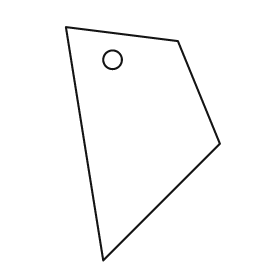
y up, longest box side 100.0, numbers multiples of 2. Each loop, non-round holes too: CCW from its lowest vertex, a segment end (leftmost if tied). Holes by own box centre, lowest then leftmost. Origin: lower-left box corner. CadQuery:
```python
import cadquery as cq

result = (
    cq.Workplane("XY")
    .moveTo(16.0, 0.0)
    .lineTo(66.0, 50.0)
    .lineTo(48.0, 94.0)
    .lineTo(0.0, 100.0)
    .close()
    .moveTo(20.0, 86.0)
    .circle(4.0)
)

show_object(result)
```